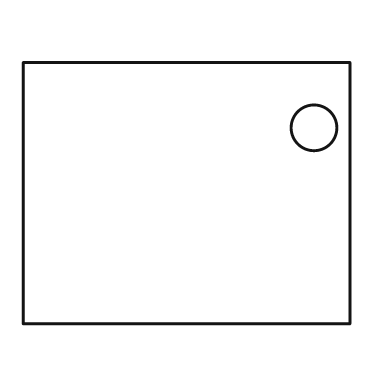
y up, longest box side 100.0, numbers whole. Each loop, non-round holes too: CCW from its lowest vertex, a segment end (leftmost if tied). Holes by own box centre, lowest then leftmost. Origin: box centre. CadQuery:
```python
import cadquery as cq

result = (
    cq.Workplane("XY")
    .moveTo(-50.0, -40.0)
    .lineTo(50.0, -40.0)
    .lineTo(50.0, 40.0)
    .lineTo(-50.0, 40.0)
    .close()
    .moveTo(39.0, 20.0)
    .circle(7.0)
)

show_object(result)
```